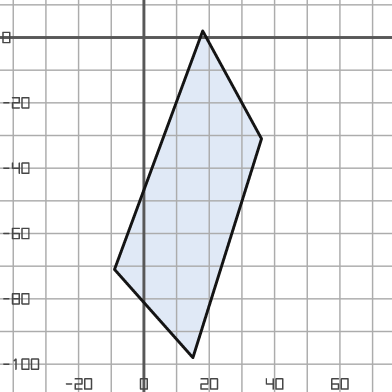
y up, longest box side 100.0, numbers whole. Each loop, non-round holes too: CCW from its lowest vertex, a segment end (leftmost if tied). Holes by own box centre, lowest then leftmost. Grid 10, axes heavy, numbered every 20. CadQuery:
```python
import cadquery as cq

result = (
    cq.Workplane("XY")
    .moveTo(15.0, -98.0)
    .lineTo(36.0, -31.0)
    .lineTo(18.0, 2.0)
    .lineTo(-9.0, -71.0)
    .close()
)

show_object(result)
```